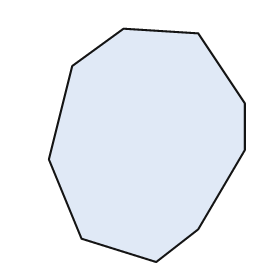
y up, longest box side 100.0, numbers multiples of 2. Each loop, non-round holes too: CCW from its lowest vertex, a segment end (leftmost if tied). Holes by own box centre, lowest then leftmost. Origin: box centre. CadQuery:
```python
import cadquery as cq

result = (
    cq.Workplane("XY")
    .moveTo(4.0, -50.0)
    .lineTo(22.0, -36.0)
    .lineTo(42.0, -2.0)
    .lineTo(42.0, 18.0)
    .lineTo(22.0, 48.0)
    .lineTo(-10.0, 50.0)
    .lineTo(-32.0, 34.0)
    .lineTo(-42.0, -6.0)
    .lineTo(-28.0, -40.0)
    .close()
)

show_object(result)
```